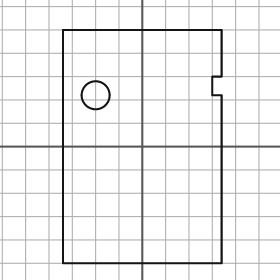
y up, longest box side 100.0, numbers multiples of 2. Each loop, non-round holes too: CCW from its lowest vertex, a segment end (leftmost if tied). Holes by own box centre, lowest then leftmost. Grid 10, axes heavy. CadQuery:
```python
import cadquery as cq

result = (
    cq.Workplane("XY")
    .moveTo(-34.0, -50.0)
    .lineTo(34.0, -50.0)
    .lineTo(34.0, 22.0)
    .lineTo(30.0, 22.0)
    .lineTo(30.0, 30.0)
    .lineTo(34.0, 30.0)
    .lineTo(34.0, 50.0)
    .lineTo(-34.0, 50.0)
    .close()
    .moveTo(-20.0, 22.0)
    .circle(6.0)
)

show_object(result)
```